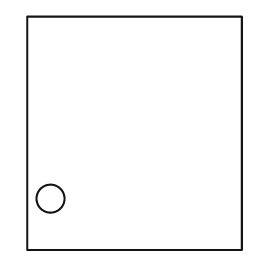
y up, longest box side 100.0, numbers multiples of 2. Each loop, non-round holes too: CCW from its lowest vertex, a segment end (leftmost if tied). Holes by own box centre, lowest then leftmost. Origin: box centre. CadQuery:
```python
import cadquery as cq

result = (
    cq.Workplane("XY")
    .moveTo(-46.0, -50.0)
    .lineTo(46.0, -50.0)
    .lineTo(46.0, 50.0)
    .lineTo(-46.0, 50.0)
    .close()
    .moveTo(-36.0, -28.0)
    .circle(6.0)
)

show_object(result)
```